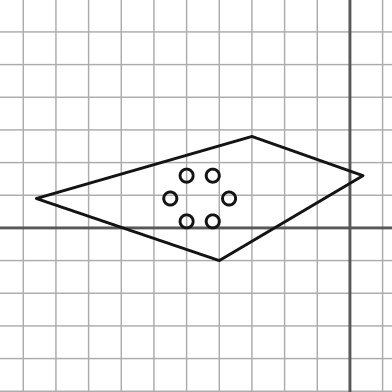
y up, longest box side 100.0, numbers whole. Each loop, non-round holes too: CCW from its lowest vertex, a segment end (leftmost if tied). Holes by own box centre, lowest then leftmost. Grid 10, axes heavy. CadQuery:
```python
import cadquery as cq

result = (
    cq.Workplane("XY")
    .moveTo(-40.0, -10.0)
    .lineTo(4.0, 16.0)
    .lineTo(-30.0, 28.0)
    .lineTo(-96.0, 9.0)
    .close()
    .moveTo(-50.0, 2.0)
    .circle(2.0)
    .moveTo(-42.0, 2.0)
    .circle(2.0)
    .moveTo(-55.0, 9.0)
    .circle(2.0)
    .moveTo(-37.0, 9.0)
    .circle(2.0)
    .moveTo(-50.0, 16.0)
    .circle(2.0)
    .moveTo(-42.0, 16.0)
    .circle(2.0)
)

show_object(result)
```